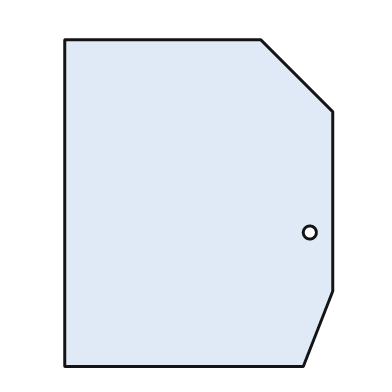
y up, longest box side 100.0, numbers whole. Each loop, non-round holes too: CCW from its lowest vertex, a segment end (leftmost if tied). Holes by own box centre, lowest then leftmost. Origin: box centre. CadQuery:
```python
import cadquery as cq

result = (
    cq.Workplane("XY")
    .moveTo(-41.0, -50.0)
    .lineTo(32.0, -50.0)
    .lineTo(41.0, -27.0)
    .lineTo(41.0, 28.0)
    .lineTo(19.0, 50.0)
    .lineTo(-41.0, 50.0)
    .close()
    .moveTo(34.0, -9.0)
    .circle(2.0)
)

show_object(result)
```